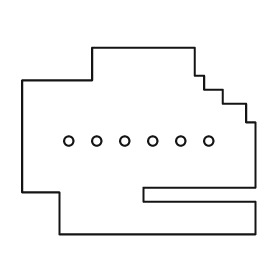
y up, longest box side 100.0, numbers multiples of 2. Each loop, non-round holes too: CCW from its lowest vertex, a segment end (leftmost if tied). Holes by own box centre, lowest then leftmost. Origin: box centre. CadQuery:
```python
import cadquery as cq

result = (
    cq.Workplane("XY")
    .moveTo(-34.0, -40.0)
    .lineTo(50.0, -40.0)
    .lineTo(50.0, -26.0)
    .lineTo(2.0, -26.0)
    .lineTo(2.0, -20.0)
    .lineTo(50.0, -20.0)
    .lineTo(50.0, 8.0)
    .lineTo(46.0, 8.0)
    .lineTo(46.0, 16.0)
    .lineTo(36.0, 16.0)
    .lineTo(36.0, 22.0)
    .lineTo(28.0, 22.0)
    .lineTo(28.0, 28.0)
    .lineTo(24.0, 28.0)
    .lineTo(24.0, 40.0)
    .lineTo(-20.0, 40.0)
    .lineTo(-20.0, 26.0)
    .lineTo(-50.0, 26.0)
    .lineTo(-50.0, -22.0)
    .lineTo(-34.0, -22.0)
    .close()
    .moveTo(-30.0, 0.0)
    .circle(2.0)
    .moveTo(-18.0, 0.0)
    .circle(2.0)
    .moveTo(-6.0, 0.0)
    .circle(2.0)
    .moveTo(6.0, 0.0)
    .circle(2.0)
    .moveTo(18.0, 0.0)
    .circle(2.0)
    .moveTo(30.0, 0.0)
    .circle(2.0)
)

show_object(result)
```